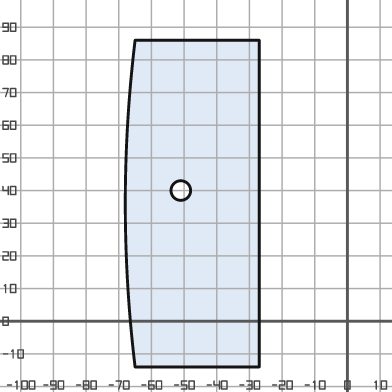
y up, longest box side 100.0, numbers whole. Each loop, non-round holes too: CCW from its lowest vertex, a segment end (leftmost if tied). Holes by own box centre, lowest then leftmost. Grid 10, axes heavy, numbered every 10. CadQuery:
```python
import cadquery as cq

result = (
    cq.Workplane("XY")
    .moveTo(-65.0, -14.0)
    .lineTo(-27.0, -14.0)
    .lineTo(-27.0, 86.0)
    .lineTo(-65.0, 86.0)
    .threePointArc((-68.0, 36.0), (-65.0, -14.0))
    .close()
    .moveTo(-51.0, 40.0)
    .circle(3.0)
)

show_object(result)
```